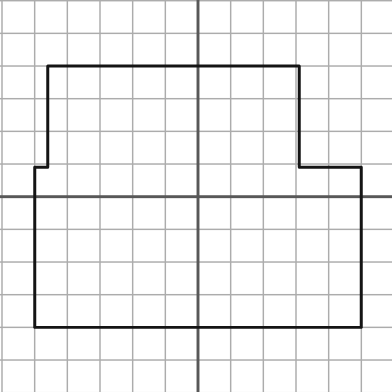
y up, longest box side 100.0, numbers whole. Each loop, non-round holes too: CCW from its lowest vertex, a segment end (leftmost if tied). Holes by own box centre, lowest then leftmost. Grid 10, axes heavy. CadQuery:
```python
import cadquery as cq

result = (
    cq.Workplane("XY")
    .moveTo(-50.0, -40.0)
    .lineTo(50.0, -40.0)
    .lineTo(50.0, 9.0)
    .lineTo(31.0, 9.0)
    .lineTo(31.0, 40.0)
    .lineTo(-46.0, 40.0)
    .lineTo(-46.0, 9.0)
    .lineTo(-50.0, 9.0)
    .close()
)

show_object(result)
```